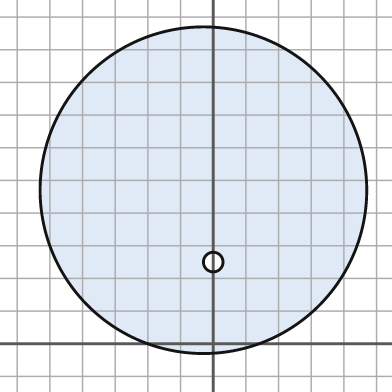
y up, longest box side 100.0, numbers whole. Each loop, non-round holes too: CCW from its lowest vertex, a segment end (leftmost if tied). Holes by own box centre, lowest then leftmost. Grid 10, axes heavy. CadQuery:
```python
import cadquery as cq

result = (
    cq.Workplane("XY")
    .moveTo(-3.0, 47.0)
    .circle(50.0)
    .moveTo(0.0, 25.0)
    .circle(3.0)
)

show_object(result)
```